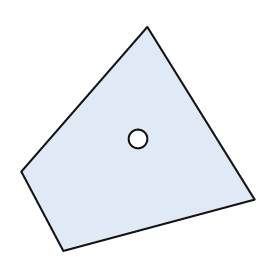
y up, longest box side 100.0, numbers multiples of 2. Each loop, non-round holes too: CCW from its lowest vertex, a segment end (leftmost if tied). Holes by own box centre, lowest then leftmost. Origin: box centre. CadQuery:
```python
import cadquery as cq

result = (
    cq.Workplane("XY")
    .moveTo(-32.0, -48.0)
    .lineTo(50.0, -26.0)
    .lineTo(4.0, 48.0)
    .lineTo(-50.0, -14.0)
    .close()
    .moveTo(0.0, 0.0)
    .circle(4.0)
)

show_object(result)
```